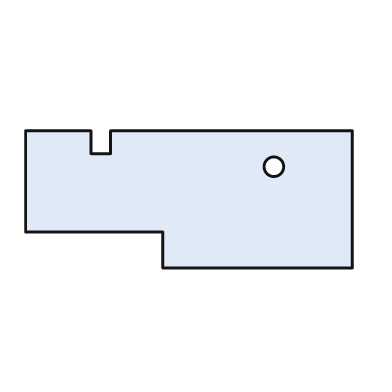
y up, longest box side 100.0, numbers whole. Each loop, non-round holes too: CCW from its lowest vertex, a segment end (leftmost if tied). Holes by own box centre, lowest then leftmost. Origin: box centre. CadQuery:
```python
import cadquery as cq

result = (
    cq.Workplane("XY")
    .moveTo(-8.0, -21.0)
    .lineTo(50.0, -21.0)
    .lineTo(50.0, 21.0)
    .lineTo(-24.0, 21.0)
    .lineTo(-24.0, 14.0)
    .lineTo(-30.0, 14.0)
    .lineTo(-30.0, 21.0)
    .lineTo(-50.0, 21.0)
    .lineTo(-50.0, -10.0)
    .lineTo(-8.0, -10.0)
    .close()
    .moveTo(26.0, 10.0)
    .circle(3.0)
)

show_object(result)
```